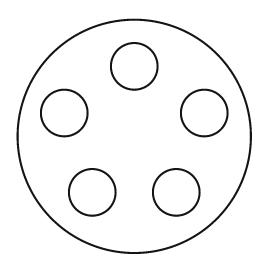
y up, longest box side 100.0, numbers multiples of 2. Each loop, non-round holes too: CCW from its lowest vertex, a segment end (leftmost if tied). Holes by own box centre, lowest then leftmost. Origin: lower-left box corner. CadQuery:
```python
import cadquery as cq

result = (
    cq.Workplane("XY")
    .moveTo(50.0, 50.0)
    .circle(50.0)
    .moveTo(32.0, 26.0)
    .circle(10.0)
    .moveTo(68.0, 26.0)
    .circle(10.0)
    .moveTo(20.0, 60.0)
    .circle(10.0)
    .moveTo(80.0, 60.0)
    .circle(10.0)
    .moveTo(50.0, 80.0)
    .circle(10.0)
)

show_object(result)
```